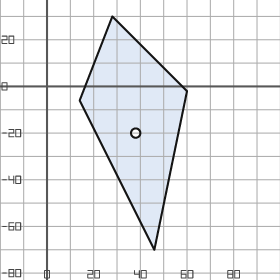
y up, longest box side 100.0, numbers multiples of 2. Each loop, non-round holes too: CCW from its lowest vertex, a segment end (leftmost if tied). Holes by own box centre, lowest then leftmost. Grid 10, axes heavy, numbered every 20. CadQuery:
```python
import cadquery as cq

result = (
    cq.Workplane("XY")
    .moveTo(46.0, -70.0)
    .lineTo(60.0, -2.0)
    .lineTo(28.0, 30.0)
    .lineTo(14.0, -6.0)
    .close()
    .moveTo(38.0, -20.0)
    .circle(2.0)
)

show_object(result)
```